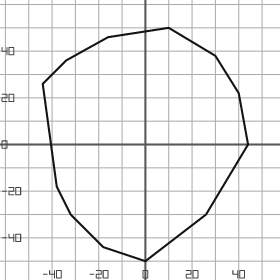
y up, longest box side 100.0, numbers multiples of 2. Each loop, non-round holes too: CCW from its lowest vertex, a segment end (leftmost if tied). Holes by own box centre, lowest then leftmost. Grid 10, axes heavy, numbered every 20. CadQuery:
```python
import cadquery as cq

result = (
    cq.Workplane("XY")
    .moveTo(0.0, -50.0)
    .lineTo(26.0, -30.0)
    .lineTo(44.0, 0.0)
    .lineTo(40.0, 22.0)
    .lineTo(30.0, 38.0)
    .lineTo(10.0, 50.0)
    .lineTo(-16.0, 46.0)
    .lineTo(-34.0, 36.0)
    .lineTo(-44.0, 26.0)
    .lineTo(-38.0, -18.0)
    .lineTo(-32.0, -30.0)
    .lineTo(-18.0, -44.0)
    .close()
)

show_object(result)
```